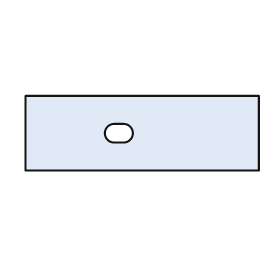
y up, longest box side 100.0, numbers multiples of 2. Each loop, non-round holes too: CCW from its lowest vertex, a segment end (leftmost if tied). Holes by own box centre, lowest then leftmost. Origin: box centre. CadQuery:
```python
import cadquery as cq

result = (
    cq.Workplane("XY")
    .moveTo(-50.0, -16.0)
    .lineTo(50.0, -16.0)
    .lineTo(50.0, 16.0)
    .lineTo(-50.0, 16.0)
    .close()
    .moveTo(-12.0, -4.0)
    .lineTo(-8.0, -4.0)
    .threePointArc((-4.0, 0.0), (-8.0, 4.0))
    .lineTo(-12.0, 4.0)
    .threePointArc((-16.0, 0.0), (-12.0, -4.0))
    .close()
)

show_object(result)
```